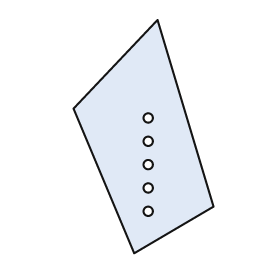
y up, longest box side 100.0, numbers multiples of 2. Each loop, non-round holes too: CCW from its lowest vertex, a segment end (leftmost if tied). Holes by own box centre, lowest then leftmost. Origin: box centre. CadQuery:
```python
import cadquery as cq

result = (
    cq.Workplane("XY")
    .moveTo(-4.0, -50.0)
    .lineTo(30.0, -30.0)
    .lineTo(6.0, 50.0)
    .lineTo(-30.0, 12.0)
    .close()
    .moveTo(2.0, -32.0)
    .circle(2.0)
    .moveTo(2.0, -22.0)
    .circle(2.0)
    .moveTo(2.0, -12.0)
    .circle(2.0)
    .moveTo(2.0, -2.0)
    .circle(2.0)
    .moveTo(2.0, 8.0)
    .circle(2.0)
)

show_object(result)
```